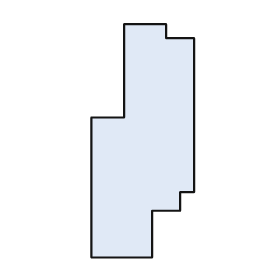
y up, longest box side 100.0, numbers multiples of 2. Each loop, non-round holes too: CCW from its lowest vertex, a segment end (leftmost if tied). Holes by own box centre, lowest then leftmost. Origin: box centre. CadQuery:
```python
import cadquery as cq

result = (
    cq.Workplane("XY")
    .moveTo(-22.0, -50.0)
    .lineTo(4.0, -50.0)
    .lineTo(4.0, -30.0)
    .lineTo(16.0, -30.0)
    .lineTo(16.0, -22.0)
    .lineTo(22.0, -22.0)
    .lineTo(22.0, 44.0)
    .lineTo(10.0, 44.0)
    .lineTo(10.0, 50.0)
    .lineTo(-8.0, 50.0)
    .lineTo(-8.0, 10.0)
    .lineTo(-22.0, 10.0)
    .close()
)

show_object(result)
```